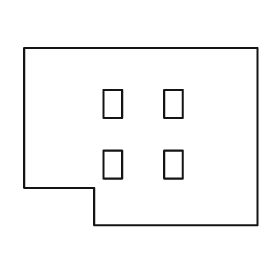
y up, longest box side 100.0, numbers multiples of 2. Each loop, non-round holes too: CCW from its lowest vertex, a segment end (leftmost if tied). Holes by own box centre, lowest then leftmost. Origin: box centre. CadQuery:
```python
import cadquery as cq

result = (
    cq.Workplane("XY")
    .moveTo(-20.0, -38.0)
    .lineTo(50.0, -38.0)
    .lineTo(50.0, 38.0)
    .lineTo(-50.0, 38.0)
    .lineTo(-50.0, -22.0)
    .lineTo(-20.0, -22.0)
    .close()
    .moveTo(-16.0, -18.0)
    .lineTo(-8.0, -18.0)
    .lineTo(-8.0, -6.0)
    .lineTo(-16.0, -6.0)
    .close()
    .moveTo(10.0, -18.0)
    .lineTo(18.0, -18.0)
    .lineTo(18.0, -6.0)
    .lineTo(10.0, -6.0)
    .close()
    .moveTo(-16.0, 8.0)
    .lineTo(-8.0, 8.0)
    .lineTo(-8.0, 20.0)
    .lineTo(-16.0, 20.0)
    .close()
    .moveTo(10.0, 8.0)
    .lineTo(18.0, 8.0)
    .lineTo(18.0, 20.0)
    .lineTo(10.0, 20.0)
    .close()
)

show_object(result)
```